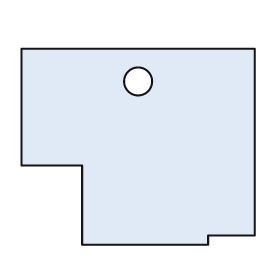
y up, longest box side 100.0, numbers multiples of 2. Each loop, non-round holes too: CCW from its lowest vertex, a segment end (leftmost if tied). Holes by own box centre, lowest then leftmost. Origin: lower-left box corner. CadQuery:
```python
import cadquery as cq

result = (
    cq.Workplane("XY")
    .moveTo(26.0, 0.0)
    .lineTo(80.0, 0.0)
    .lineTo(80.0, 4.0)
    .lineTo(100.0, 4.0)
    .lineTo(100.0, 84.0)
    .lineTo(0.0, 84.0)
    .lineTo(0.0, 34.0)
    .lineTo(26.0, 34.0)
    .close()
    .moveTo(50.0, 70.0)
    .circle(6.0)
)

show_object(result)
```